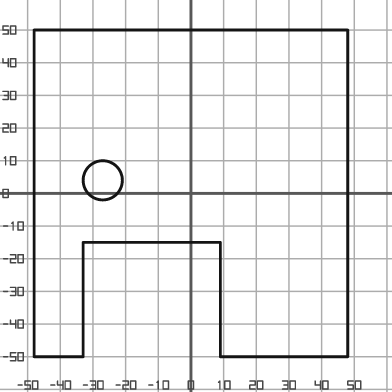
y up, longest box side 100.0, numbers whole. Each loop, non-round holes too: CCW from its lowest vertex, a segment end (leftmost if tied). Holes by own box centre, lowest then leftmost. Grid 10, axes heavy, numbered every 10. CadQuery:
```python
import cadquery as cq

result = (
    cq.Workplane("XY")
    .moveTo(-48.0, -50.0)
    .lineTo(-33.0, -50.0)
    .lineTo(-33.0, -15.0)
    .lineTo(9.0, -15.0)
    .lineTo(9.0, -50.0)
    .lineTo(48.0, -50.0)
    .lineTo(48.0, 50.0)
    .lineTo(-48.0, 50.0)
    .close()
    .moveTo(-27.0, 4.0)
    .circle(6.0)
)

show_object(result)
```